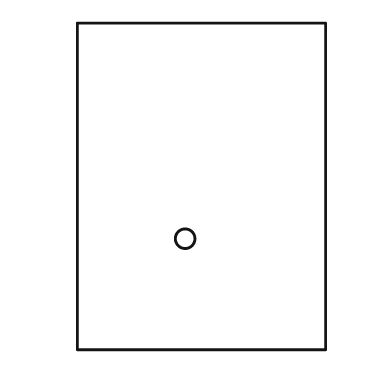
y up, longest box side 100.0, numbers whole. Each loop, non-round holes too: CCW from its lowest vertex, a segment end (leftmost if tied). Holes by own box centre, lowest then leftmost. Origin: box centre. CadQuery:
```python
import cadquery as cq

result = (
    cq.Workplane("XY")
    .moveTo(-38.0, -50.0)
    .lineTo(38.0, -50.0)
    .lineTo(38.0, 50.0)
    .lineTo(-38.0, 50.0)
    .close()
    .moveTo(-5.0, -16.0)
    .circle(3.0)
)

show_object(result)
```